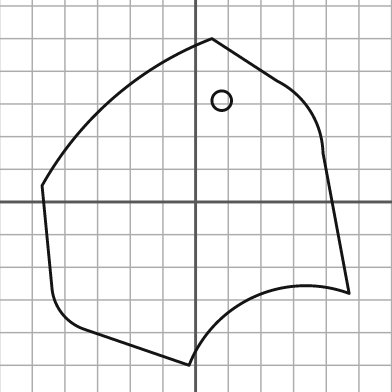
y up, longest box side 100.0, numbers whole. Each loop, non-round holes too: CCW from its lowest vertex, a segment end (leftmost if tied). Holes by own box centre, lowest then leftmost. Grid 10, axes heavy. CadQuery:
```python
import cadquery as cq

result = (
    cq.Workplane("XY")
    .moveTo(-2.0, -50.0)
    .threePointArc((18.0, -29.0), (47.0, -28.0))
    .lineTo(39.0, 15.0)
    .threePointArc((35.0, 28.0), (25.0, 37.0))
    .lineTo(5.0, 50.0)
    .threePointArc((-25.0, 32.0), (-47.0, 5.0))
    .lineTo(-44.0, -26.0)
    .threePointArc((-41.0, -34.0), (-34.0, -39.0))
    .close()
    .moveTo(8.0, 31.0)
    .circle(3.0)
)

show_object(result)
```